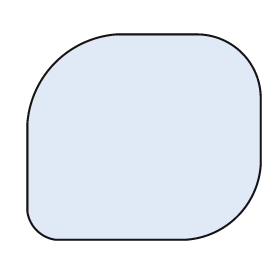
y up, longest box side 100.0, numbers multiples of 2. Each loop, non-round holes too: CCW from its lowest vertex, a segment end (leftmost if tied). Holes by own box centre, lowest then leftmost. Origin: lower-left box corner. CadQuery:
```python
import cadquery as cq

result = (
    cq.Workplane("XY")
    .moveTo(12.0, 0.0)
    .lineTo(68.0, 0.0)
    .threePointArc((90.0, 10.0), (100.0, 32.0))
    .lineTo(100.0, 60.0)
    .threePointArc((92.0, 80.0), (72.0, 88.0))
    .lineTo(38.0, 88.0)
    .threePointArc((12.0, 76.0), (0.0, 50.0))
    .lineTo(0.0, 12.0)
    .threePointArc((4.0, 4.0), (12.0, 0.0))
    .close()
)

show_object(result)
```